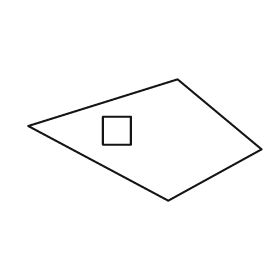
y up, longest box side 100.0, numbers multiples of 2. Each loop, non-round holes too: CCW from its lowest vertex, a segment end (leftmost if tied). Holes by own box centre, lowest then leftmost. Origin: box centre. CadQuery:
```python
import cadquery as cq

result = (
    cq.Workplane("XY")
    .moveTo(10.0, -26.0)
    .lineTo(50.0, -4.0)
    .lineTo(14.0, 26.0)
    .lineTo(-50.0, 6.0)
    .close()
    .moveTo(-18.0, -2.0)
    .lineTo(-6.0, -2.0)
    .lineTo(-6.0, 10.0)
    .lineTo(-18.0, 10.0)
    .close()
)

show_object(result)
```